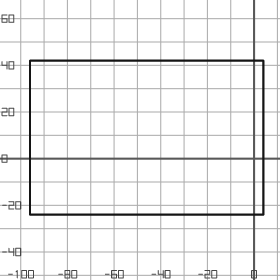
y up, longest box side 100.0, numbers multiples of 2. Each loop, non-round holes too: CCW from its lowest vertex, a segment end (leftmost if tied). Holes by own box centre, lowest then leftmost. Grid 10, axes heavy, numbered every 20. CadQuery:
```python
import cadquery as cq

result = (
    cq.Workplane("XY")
    .moveTo(-96.0, -24.0)
    .lineTo(4.0, -24.0)
    .lineTo(4.0, 42.0)
    .lineTo(-96.0, 42.0)
    .close()
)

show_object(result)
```